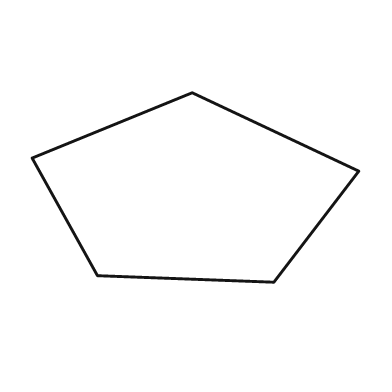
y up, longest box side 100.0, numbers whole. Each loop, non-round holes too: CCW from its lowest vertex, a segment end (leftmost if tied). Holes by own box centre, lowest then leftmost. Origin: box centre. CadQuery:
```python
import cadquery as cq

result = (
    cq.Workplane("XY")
    .moveTo(24.0, -29.0)
    .lineTo(50.0, 5.0)
    .lineTo(-1.0, 29.0)
    .lineTo(-50.0, 9.0)
    .lineTo(-30.0, -27.0)
    .close()
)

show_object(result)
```